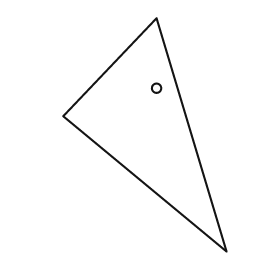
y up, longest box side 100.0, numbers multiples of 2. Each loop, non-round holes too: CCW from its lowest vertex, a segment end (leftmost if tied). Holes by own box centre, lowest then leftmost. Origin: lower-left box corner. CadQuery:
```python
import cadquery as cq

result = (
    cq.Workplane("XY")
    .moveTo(70.0, 0.0)
    .lineTo(40.0, 100.0)
    .lineTo(0.0, 58.0)
    .close()
    .moveTo(40.0, 70.0)
    .circle(2.0)
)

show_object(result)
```